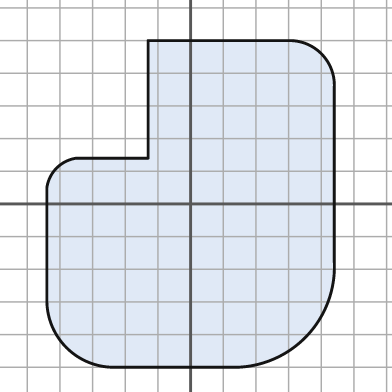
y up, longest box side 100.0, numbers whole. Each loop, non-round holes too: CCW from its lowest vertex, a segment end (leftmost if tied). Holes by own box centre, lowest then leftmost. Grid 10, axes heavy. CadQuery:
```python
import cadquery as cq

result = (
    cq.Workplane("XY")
    .moveTo(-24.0, -50.0)
    .lineTo(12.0, -50.0)
    .threePointArc((35.0, -41.0), (44.0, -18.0))
    .lineTo(44.0, 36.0)
    .threePointArc((40.0, 46.0), (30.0, 50.0))
    .lineTo(-13.0, 50.0)
    .lineTo(-13.0, 14.0)
    .lineTo(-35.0, 14.0)
    .threePointArc((-41.0, 11.0), (-44.0, 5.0))
    .lineTo(-44.0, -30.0)
    .threePointArc((-38.0, -44.0), (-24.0, -50.0))
    .close()
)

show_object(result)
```